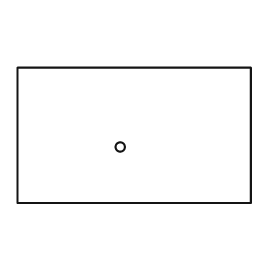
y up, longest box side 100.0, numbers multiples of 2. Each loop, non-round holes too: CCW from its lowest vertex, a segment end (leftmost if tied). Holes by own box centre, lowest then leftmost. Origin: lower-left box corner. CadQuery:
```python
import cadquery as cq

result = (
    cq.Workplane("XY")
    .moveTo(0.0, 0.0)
    .lineTo(100.0, 0.0)
    .lineTo(100.0, 58.0)
    .lineTo(0.0, 58.0)
    .close()
    .moveTo(44.0, 24.0)
    .circle(2.0)
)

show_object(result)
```